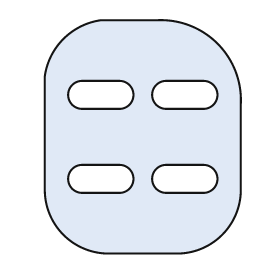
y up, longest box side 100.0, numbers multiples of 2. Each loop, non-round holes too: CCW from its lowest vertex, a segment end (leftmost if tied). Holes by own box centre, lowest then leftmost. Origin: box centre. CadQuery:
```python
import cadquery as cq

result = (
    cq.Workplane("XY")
    .moveTo(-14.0, -50.0)
    .lineTo(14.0, -50.0)
    .threePointArc((34.0, -42.0), (42.0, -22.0))
    .lineTo(42.0, 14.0)
    .threePointArc((32.0, 40.0), (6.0, 50.0))
    .lineTo(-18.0, 50.0)
    .threePointArc((-34.0, 42.0), (-42.0, 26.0))
    .lineTo(-42.0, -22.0)
    .threePointArc((-34.0, -42.0), (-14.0, -50.0))
    .close()
    .moveTo(-26.0, -24.0)
    .lineTo(-10.0, -24.0)
    .threePointArc((-4.0, -18.0), (-10.0, -12.0))
    .lineTo(-26.0, -12.0)
    .threePointArc((-32.0, -18.0), (-26.0, -24.0))
    .close()
    .moveTo(10.0, -24.0)
    .lineTo(26.0, -24.0)
    .threePointArc((32.0, -18.0), (26.0, -12.0))
    .lineTo(10.0, -12.0)
    .threePointArc((4.0, -18.0), (10.0, -24.0))
    .close()
    .moveTo(-26.0, 12.0)
    .lineTo(-10.0, 12.0)
    .threePointArc((-4.0, 18.0), (-10.0, 24.0))
    .lineTo(-26.0, 24.0)
    .threePointArc((-32.0, 18.0), (-26.0, 12.0))
    .close()
    .moveTo(10.0, 12.0)
    .lineTo(26.0, 12.0)
    .threePointArc((32.0, 18.0), (26.0, 24.0))
    .lineTo(10.0, 24.0)
    .threePointArc((4.0, 18.0), (10.0, 12.0))
    .close()
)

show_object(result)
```